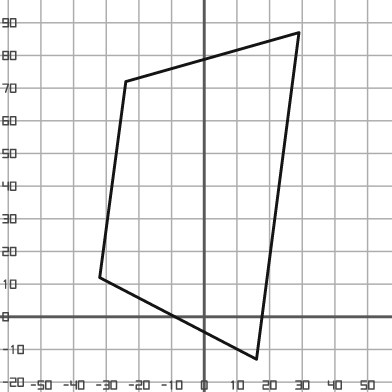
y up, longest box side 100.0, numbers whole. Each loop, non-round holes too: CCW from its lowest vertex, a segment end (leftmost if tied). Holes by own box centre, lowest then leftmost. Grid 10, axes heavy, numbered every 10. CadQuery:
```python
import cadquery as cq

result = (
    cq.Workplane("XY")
    .moveTo(16.0, -13.0)
    .lineTo(29.0, 87.0)
    .lineTo(-24.0, 72.0)
    .lineTo(-32.0, 12.0)
    .close()
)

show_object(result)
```